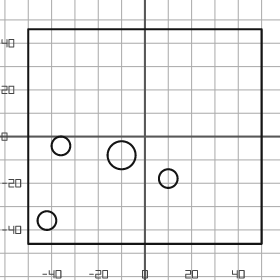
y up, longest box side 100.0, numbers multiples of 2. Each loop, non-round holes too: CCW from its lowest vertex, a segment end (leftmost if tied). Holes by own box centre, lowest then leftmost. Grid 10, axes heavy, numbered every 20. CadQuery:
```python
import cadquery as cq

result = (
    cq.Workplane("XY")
    .moveTo(-50.0, -46.0)
    .lineTo(50.0, -46.0)
    .lineTo(50.0, 46.0)
    .lineTo(-50.0, 46.0)
    .close()
    .moveTo(-42.0, -36.0)
    .circle(4.0)
    .moveTo(10.0, -18.0)
    .circle(4.0)
    .moveTo(-10.0, -8.0)
    .circle(6.0)
    .moveTo(-36.0, -4.0)
    .circle(4.0)
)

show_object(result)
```